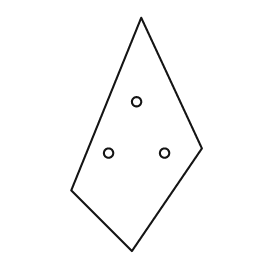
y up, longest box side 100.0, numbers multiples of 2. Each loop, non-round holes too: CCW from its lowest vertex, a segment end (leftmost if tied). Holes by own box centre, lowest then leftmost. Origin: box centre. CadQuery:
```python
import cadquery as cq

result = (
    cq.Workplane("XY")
    .moveTo(-2.0, -50.0)
    .lineTo(28.0, -6.0)
    .lineTo(2.0, 50.0)
    .lineTo(-28.0, -24.0)
    .close()
    .moveTo(-12.0, -8.0)
    .circle(2.0)
    .moveTo(12.0, -8.0)
    .circle(2.0)
    .moveTo(0.0, 14.0)
    .circle(2.0)
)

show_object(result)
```